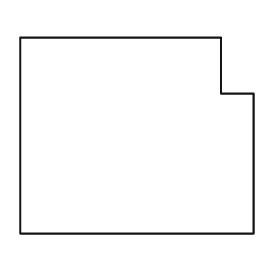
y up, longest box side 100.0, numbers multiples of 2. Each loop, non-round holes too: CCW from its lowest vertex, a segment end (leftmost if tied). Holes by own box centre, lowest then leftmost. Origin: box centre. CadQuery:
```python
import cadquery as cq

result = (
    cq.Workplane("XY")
    .moveTo(-50.0, -42.0)
    .lineTo(50.0, -42.0)
    .lineTo(50.0, 18.0)
    .lineTo(36.0, 18.0)
    .lineTo(36.0, 42.0)
    .lineTo(-50.0, 42.0)
    .close()
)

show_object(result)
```